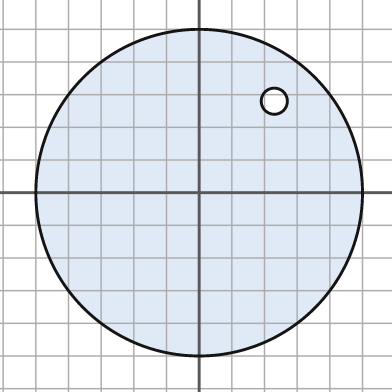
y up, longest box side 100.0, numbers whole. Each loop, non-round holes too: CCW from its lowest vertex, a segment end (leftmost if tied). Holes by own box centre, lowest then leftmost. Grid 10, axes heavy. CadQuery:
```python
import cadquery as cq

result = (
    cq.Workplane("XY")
    .moveTo(0.0, 0.0)
    .circle(50.0)
    .moveTo(23.0, 28.0)
    .circle(4.0)
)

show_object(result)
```